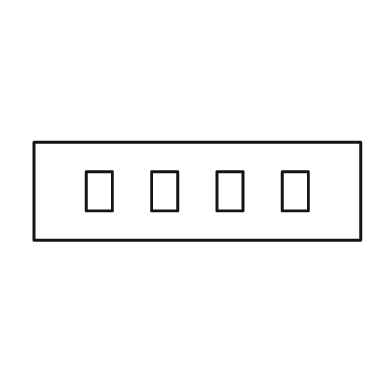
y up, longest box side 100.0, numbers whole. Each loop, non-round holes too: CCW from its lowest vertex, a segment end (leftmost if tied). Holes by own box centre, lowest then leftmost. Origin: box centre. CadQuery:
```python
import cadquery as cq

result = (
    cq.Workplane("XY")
    .moveTo(-50.0, -15.0)
    .lineTo(50.0, -15.0)
    .lineTo(50.0, 15.0)
    .lineTo(-50.0, 15.0)
    .close()
    .moveTo(-34.0, -6.0)
    .lineTo(-26.0, -6.0)
    .lineTo(-26.0, 6.0)
    .lineTo(-34.0, 6.0)
    .close()
    .moveTo(-14.0, -6.0)
    .lineTo(-6.0, -6.0)
    .lineTo(-6.0, 6.0)
    .lineTo(-14.0, 6.0)
    .close()
    .moveTo(6.0, -6.0)
    .lineTo(14.0, -6.0)
    .lineTo(14.0, 6.0)
    .lineTo(6.0, 6.0)
    .close()
    .moveTo(26.0, -6.0)
    .lineTo(34.0, -6.0)
    .lineTo(34.0, 6.0)
    .lineTo(26.0, 6.0)
    .close()
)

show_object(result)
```